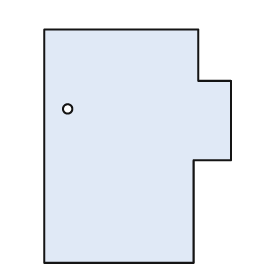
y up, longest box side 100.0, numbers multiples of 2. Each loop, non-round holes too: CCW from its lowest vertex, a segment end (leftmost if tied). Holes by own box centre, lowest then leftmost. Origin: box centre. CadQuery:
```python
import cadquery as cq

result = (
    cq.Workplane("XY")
    .moveTo(-40.0, -50.0)
    .lineTo(24.0, -50.0)
    .lineTo(24.0, -6.0)
    .lineTo(40.0, -6.0)
    .lineTo(40.0, 28.0)
    .lineTo(26.0, 28.0)
    .lineTo(26.0, 50.0)
    .lineTo(-40.0, 50.0)
    .close()
    .moveTo(-30.0, 16.0)
    .circle(2.0)
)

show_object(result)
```